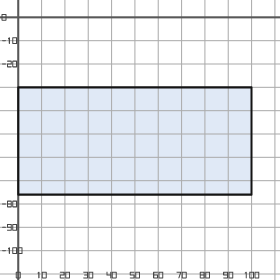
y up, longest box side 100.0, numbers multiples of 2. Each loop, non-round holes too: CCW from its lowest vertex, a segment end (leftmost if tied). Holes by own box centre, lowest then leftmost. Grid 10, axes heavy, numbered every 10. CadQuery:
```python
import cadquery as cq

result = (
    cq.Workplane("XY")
    .moveTo(0.0, -76.0)
    .lineTo(100.0, -76.0)
    .lineTo(100.0, -30.0)
    .lineTo(0.0, -30.0)
    .close()
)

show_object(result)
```